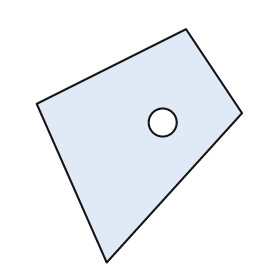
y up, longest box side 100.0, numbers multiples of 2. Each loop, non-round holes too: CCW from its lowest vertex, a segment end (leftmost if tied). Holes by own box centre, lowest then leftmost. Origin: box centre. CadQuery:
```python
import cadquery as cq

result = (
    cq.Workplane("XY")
    .moveTo(-14.0, -50.0)
    .lineTo(44.0, 14.0)
    .lineTo(20.0, 50.0)
    .lineTo(-44.0, 18.0)
    .close()
    .moveTo(10.0, 10.0)
    .circle(6.0)
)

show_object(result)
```